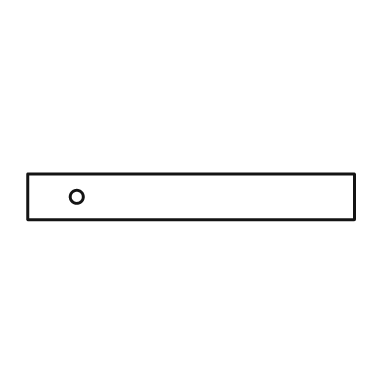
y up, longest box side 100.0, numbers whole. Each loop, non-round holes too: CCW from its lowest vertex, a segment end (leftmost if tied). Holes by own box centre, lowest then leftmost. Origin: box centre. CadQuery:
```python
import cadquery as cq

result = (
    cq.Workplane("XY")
    .moveTo(-50.0, -7.0)
    .lineTo(50.0, -7.0)
    .lineTo(50.0, 7.0)
    .lineTo(-50.0, 7.0)
    .close()
    .moveTo(-35.0, 0.0)
    .circle(2.0)
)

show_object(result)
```